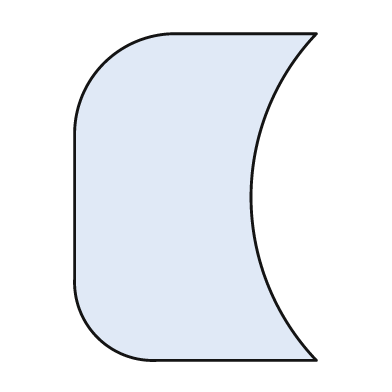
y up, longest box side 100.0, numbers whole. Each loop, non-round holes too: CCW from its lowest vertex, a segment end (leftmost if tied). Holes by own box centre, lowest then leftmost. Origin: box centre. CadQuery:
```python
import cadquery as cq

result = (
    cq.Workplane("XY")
    .moveTo(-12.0, -50.0)
    .lineTo(37.0, -50.0)
    .threePointArc((17.0, 0.0), (37.0, 50.0))
    .lineTo(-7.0, 50.0)
    .threePointArc((-28.0, 41.0), (-37.0, 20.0))
    .lineTo(-37.0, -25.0)
    .threePointArc((-30.0, -43.0), (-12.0, -50.0))
    .close()
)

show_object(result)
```